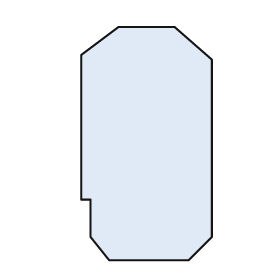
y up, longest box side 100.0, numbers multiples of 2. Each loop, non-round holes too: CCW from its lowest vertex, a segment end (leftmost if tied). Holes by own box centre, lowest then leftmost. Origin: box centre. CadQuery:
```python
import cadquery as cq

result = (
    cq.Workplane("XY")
    .moveTo(-16.0, -50.0)
    .lineTo(18.0, -50.0)
    .lineTo(28.0, -40.0)
    .lineTo(28.0, 36.0)
    .lineTo(12.0, 50.0)
    .lineTo(-12.0, 50.0)
    .lineTo(-28.0, 38.0)
    .lineTo(-28.0, -24.0)
    .lineTo(-24.0, -24.0)
    .lineTo(-24.0, -40.0)
    .close()
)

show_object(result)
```